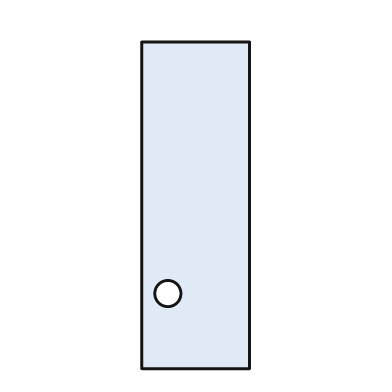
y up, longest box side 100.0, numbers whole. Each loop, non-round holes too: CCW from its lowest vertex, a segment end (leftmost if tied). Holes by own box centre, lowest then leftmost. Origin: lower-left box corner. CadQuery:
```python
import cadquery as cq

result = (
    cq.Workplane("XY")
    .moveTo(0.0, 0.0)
    .lineTo(33.0, 0.0)
    .lineTo(33.0, 100.0)
    .lineTo(0.0, 100.0)
    .close()
    .moveTo(8.0, 23.0)
    .circle(4.0)
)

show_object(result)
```